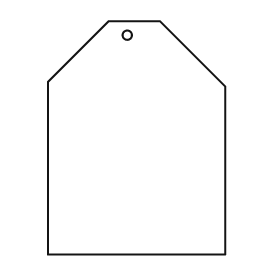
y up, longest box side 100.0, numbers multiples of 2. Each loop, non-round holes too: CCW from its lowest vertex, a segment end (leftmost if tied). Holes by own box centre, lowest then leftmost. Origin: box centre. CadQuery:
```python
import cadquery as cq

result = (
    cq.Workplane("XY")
    .moveTo(-38.0, -50.0)
    .lineTo(38.0, -50.0)
    .lineTo(38.0, 22.0)
    .lineTo(10.0, 50.0)
    .lineTo(-12.0, 50.0)
    .lineTo(-38.0, 24.0)
    .close()
    .moveTo(-4.0, 44.0)
    .circle(2.0)
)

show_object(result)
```